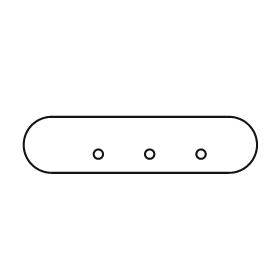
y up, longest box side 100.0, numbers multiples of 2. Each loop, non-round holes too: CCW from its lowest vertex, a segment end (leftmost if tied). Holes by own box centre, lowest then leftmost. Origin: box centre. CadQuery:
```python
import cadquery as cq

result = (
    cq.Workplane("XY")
    .moveTo(-38.0, -12.0)
    .lineTo(38.0, -12.0)
    .threePointArc((50.0, 0.0), (38.0, 12.0))
    .lineTo(-38.0, 12.0)
    .threePointArc((-50.0, 0.0), (-38.0, -12.0))
    .close()
    .moveTo(-18.0, -4.0)
    .circle(2.0)
    .moveTo(4.0, -4.0)
    .circle(2.0)
    .moveTo(26.0, -4.0)
    .circle(2.0)
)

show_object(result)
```